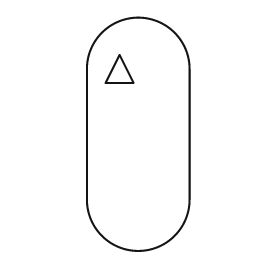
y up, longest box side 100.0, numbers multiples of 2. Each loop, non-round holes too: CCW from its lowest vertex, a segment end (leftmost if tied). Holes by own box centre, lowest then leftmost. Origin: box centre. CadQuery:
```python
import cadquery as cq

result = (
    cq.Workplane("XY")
    .moveTo(-22.0, -28.0)
    .threePointArc((0.0, -50.0), (22.0, -28.0))
    .lineTo(22.0, 28.0)
    .threePointArc((0.0, 50.0), (-22.0, 28.0))
    .close()
    .moveTo(-14.0, 22.0)
    .lineTo(-2.0, 22.0)
    .lineTo(-8.0, 34.0)
    .close()
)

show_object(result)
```